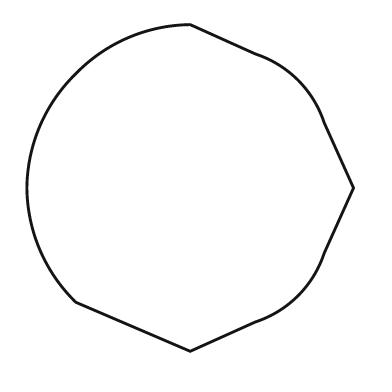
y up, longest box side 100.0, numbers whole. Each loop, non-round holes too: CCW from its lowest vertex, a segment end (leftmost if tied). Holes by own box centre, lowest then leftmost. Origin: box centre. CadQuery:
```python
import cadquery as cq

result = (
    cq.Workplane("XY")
    .moveTo(0.0, -50.0)
    .lineTo(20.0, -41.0)
    .threePointArc((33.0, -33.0), (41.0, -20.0))
    .lineTo(50.0, 0.0)
    .lineTo(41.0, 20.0)
    .threePointArc((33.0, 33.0), (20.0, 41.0))
    .lineTo(0.0, 50.0)
    .threePointArc((-19.0, 46.0), (-35.0, 35.0))
    .threePointArc((-46.0, 19.0), (-50.0, 0.0))
    .threePointArc((-46.0, -19.0), (-35.0, -35.0))
    .close()
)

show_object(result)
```